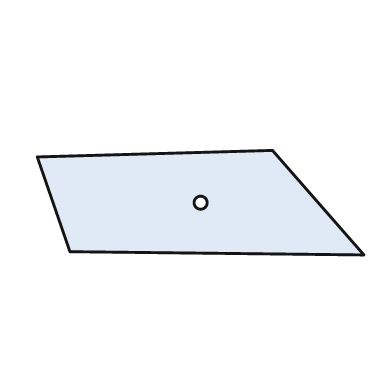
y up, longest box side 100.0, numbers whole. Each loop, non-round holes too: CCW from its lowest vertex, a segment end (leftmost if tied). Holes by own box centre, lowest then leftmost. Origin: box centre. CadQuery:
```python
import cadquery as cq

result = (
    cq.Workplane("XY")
    .moveTo(50.0, -16.0)
    .lineTo(22.0, 16.0)
    .lineTo(-50.0, 14.0)
    .lineTo(-40.0, -15.0)
    .close()
    .moveTo(0.0, 0.0)
    .circle(2.0)
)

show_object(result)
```